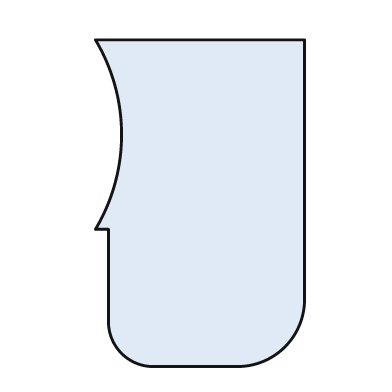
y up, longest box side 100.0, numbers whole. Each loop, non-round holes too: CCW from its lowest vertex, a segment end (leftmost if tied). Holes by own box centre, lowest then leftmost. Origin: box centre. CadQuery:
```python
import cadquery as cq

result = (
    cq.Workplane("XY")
    .moveTo(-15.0, -50.0)
    .lineTo(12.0, -50.0)
    .threePointArc((26.0, -44.0), (32.0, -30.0))
    .lineTo(32.0, 50.0)
    .lineTo(-32.0, 50.0)
    .threePointArc((-24.0, 21.0), (-32.0, -8.0))
    .lineTo(-28.0, -8.0)
    .lineTo(-28.0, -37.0)
    .threePointArc((-24.0, -46.0), (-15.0, -50.0))
    .close()
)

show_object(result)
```